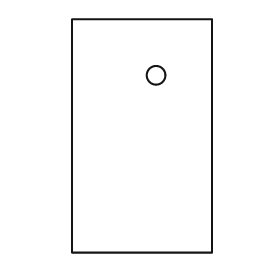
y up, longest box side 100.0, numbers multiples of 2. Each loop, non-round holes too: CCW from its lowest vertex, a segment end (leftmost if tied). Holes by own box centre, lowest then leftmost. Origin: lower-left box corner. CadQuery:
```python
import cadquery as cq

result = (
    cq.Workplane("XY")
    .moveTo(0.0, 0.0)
    .lineTo(60.0, 0.0)
    .lineTo(60.0, 100.0)
    .lineTo(0.0, 100.0)
    .close()
    .moveTo(36.0, 76.0)
    .circle(4.0)
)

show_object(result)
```